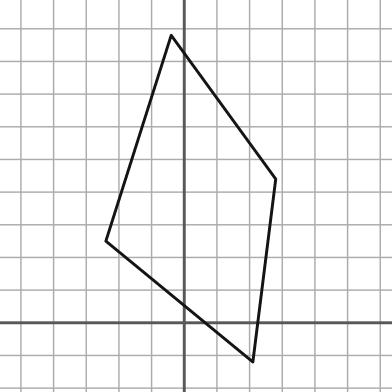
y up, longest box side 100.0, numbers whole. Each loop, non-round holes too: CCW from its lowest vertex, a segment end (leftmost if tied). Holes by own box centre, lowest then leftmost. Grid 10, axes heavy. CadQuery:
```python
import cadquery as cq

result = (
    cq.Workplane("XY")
    .moveTo(21.0, -12.0)
    .lineTo(28.0, 44.0)
    .lineTo(-4.0, 88.0)
    .lineTo(-24.0, 25.0)
    .close()
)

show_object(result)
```